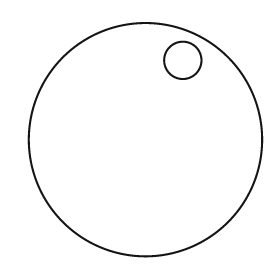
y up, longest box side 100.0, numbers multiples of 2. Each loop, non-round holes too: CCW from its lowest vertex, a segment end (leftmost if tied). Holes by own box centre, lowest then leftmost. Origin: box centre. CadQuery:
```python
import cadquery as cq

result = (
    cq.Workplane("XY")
    .moveTo(0.0, 0.0)
    .circle(50.0)
    .moveTo(16.0, 34.0)
    .circle(8.0)
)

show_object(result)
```